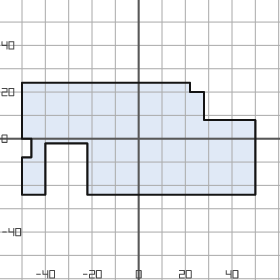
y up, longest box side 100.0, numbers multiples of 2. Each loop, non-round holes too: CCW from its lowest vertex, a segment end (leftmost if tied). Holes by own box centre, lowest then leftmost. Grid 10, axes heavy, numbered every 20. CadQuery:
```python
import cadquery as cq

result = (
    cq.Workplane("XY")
    .moveTo(-50.0, -24.0)
    .lineTo(-40.0, -24.0)
    .lineTo(-40.0, -2.0)
    .lineTo(-22.0, -2.0)
    .lineTo(-22.0, -24.0)
    .lineTo(50.0, -24.0)
    .lineTo(50.0, 8.0)
    .lineTo(28.0, 8.0)
    .lineTo(28.0, 20.0)
    .lineTo(22.0, 20.0)
    .lineTo(22.0, 24.0)
    .lineTo(-50.0, 24.0)
    .lineTo(-50.0, 0.0)
    .lineTo(-46.0, 0.0)
    .lineTo(-46.0, -8.0)
    .lineTo(-50.0, -8.0)
    .close()
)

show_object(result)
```